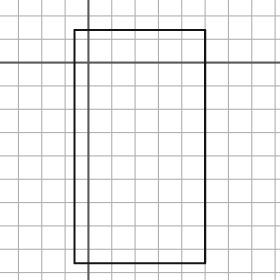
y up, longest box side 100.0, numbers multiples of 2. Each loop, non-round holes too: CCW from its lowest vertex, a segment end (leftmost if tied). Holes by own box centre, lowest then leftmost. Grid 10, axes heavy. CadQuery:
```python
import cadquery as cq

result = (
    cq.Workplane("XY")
    .moveTo(-6.0, -86.0)
    .lineTo(50.0, -86.0)
    .lineTo(50.0, 14.0)
    .lineTo(-6.0, 14.0)
    .close()
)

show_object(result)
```